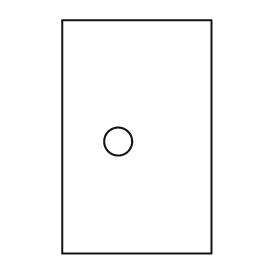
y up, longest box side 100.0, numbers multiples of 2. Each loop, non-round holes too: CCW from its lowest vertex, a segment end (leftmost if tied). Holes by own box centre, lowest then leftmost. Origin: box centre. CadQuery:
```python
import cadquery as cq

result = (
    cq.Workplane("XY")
    .moveTo(-32.0, -50.0)
    .lineTo(32.0, -50.0)
    .lineTo(32.0, 50.0)
    .lineTo(-32.0, 50.0)
    .close()
    .moveTo(-8.0, -2.0)
    .circle(6.0)
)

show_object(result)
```